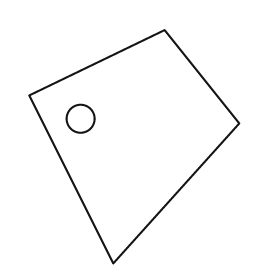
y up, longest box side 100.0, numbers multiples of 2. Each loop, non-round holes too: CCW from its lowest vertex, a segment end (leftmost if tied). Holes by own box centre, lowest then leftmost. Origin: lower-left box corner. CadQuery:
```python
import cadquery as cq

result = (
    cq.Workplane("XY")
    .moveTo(36.0, 0.0)
    .lineTo(90.0, 60.0)
    .lineTo(58.0, 100.0)
    .lineTo(0.0, 72.0)
    .close()
    .moveTo(22.0, 62.0)
    .circle(6.0)
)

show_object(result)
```